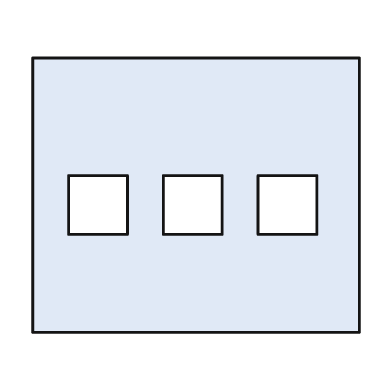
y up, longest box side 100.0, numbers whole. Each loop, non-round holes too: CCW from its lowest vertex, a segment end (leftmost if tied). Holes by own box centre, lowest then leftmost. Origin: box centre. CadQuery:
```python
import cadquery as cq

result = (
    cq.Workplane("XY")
    .moveTo(-50.0, -42.0)
    .lineTo(50.0, -42.0)
    .lineTo(50.0, 42.0)
    .lineTo(-50.0, 42.0)
    .close()
    .moveTo(-39.0, -12.0)
    .lineTo(-21.0, -12.0)
    .lineTo(-21.0, 6.0)
    .lineTo(-39.0, 6.0)
    .close()
    .moveTo(-10.0, -12.0)
    .lineTo(8.0, -12.0)
    .lineTo(8.0, 6.0)
    .lineTo(-10.0, 6.0)
    .close()
    .moveTo(19.0, -12.0)
    .lineTo(37.0, -12.0)
    .lineTo(37.0, 6.0)
    .lineTo(19.0, 6.0)
    .close()
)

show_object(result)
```